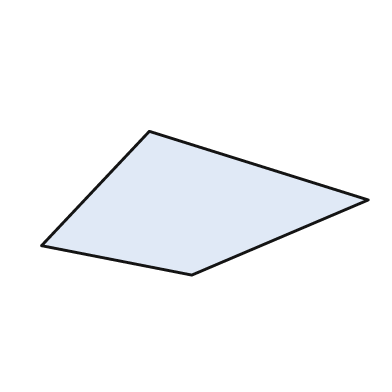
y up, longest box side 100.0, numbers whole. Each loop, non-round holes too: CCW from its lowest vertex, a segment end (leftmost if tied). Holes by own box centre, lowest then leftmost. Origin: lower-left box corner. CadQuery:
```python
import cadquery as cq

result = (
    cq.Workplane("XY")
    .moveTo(46.0, 0.0)
    .lineTo(100.0, 23.0)
    .lineTo(33.0, 44.0)
    .lineTo(0.0, 9.0)
    .close()
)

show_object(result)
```